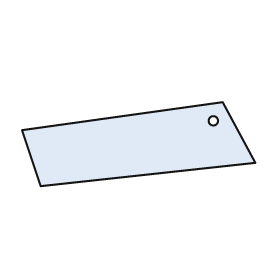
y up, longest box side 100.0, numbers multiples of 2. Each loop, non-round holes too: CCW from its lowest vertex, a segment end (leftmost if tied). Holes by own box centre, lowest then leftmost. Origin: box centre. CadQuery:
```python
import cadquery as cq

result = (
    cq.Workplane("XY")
    .moveTo(-42.0, -18.0)
    .lineTo(50.0, -8.0)
    .lineTo(36.0, 18.0)
    .lineTo(-50.0, 6.0)
    .close()
    .moveTo(32.0, 10.0)
    .circle(2.0)
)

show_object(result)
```